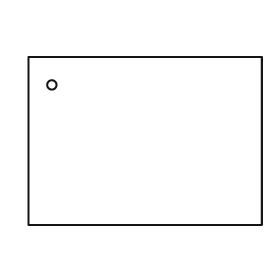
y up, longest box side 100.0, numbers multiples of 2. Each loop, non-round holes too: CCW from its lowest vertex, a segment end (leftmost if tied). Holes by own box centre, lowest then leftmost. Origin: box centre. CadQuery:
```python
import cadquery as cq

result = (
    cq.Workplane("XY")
    .moveTo(-50.0, -36.0)
    .lineTo(50.0, -36.0)
    .lineTo(50.0, 36.0)
    .lineTo(-50.0, 36.0)
    .close()
    .moveTo(-40.0, 24.0)
    .circle(2.0)
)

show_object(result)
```